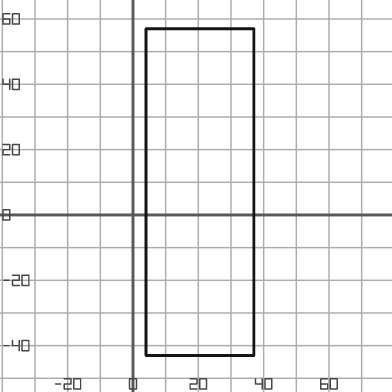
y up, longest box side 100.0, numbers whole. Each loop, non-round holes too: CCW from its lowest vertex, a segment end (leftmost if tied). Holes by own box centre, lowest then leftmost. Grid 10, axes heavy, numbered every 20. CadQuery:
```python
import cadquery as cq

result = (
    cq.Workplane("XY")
    .moveTo(4.0, -43.0)
    .lineTo(37.0, -43.0)
    .lineTo(37.0, 57.0)
    .lineTo(4.0, 57.0)
    .close()
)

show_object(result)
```